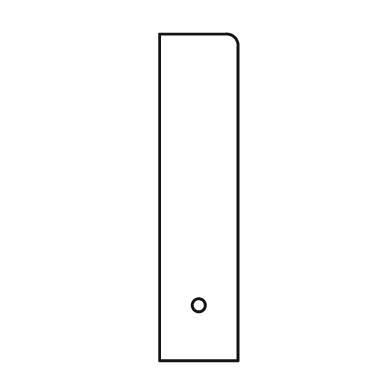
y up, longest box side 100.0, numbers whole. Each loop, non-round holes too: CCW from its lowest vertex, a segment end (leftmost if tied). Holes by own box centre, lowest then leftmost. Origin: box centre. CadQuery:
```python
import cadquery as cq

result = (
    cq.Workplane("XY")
    .moveTo(-12.0, -50.0)
    .lineTo(12.0, -50.0)
    .lineTo(12.0, 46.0)
    .threePointArc((11.0, 49.0), (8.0, 50.0))
    .lineTo(-12.0, 50.0)
    .close()
    .moveTo(0.0, -33.0)
    .circle(2.0)
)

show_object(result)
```